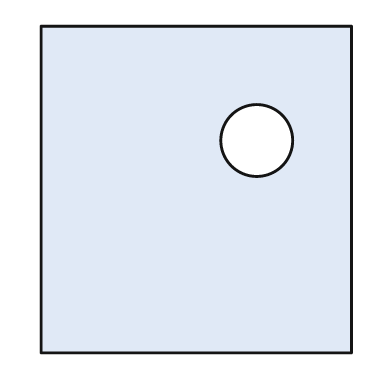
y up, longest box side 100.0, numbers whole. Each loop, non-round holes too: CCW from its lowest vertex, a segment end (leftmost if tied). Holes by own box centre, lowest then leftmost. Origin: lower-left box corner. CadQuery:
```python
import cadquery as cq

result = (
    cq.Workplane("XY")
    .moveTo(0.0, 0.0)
    .lineTo(95.0, 0.0)
    .lineTo(95.0, 100.0)
    .lineTo(0.0, 100.0)
    .close()
    .moveTo(66.0, 65.0)
    .circle(11.0)
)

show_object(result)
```